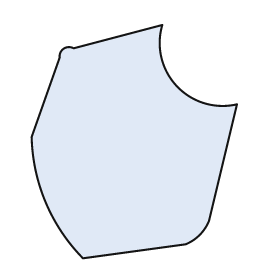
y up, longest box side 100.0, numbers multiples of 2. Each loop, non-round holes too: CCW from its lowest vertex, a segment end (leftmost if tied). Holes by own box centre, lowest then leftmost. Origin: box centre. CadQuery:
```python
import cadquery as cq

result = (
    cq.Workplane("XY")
    .moveTo(-22.0, -50.0)
    .lineTo(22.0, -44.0)
    .threePointArc((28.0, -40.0), (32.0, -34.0))
    .lineTo(44.0, 16.0)
    .threePointArc((18.0, 24.0), (12.0, 50.0))
    .lineTo(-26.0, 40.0)
    .threePointArc((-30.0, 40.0), (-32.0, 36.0))
    .lineTo(-44.0, 2.0)
    .threePointArc((-38.0, -26.0), (-22.0, -50.0))
    .close()
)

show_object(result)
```